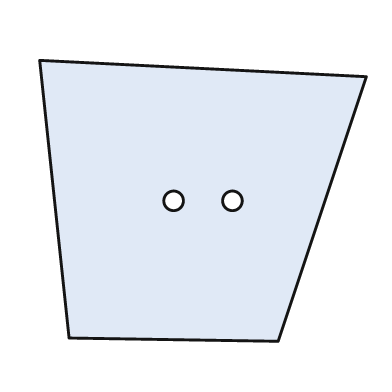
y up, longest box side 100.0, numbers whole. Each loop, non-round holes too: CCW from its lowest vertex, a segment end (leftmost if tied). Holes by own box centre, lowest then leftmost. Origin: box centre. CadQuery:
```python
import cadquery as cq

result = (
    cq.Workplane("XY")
    .moveTo(23.0, -43.0)
    .lineTo(50.0, 38.0)
    .lineTo(-50.0, 43.0)
    .lineTo(-41.0, -42.0)
    .close()
    .moveTo(-9.0, 0.0)
    .circle(3.0)
    .moveTo(9.0, 0.0)
    .circle(3.0)
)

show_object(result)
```